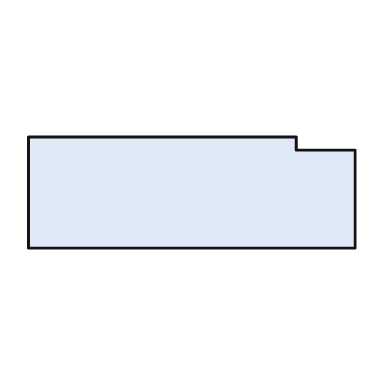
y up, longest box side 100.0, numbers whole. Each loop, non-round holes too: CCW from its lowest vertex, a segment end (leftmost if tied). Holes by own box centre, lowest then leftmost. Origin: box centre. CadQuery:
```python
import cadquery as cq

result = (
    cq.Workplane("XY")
    .moveTo(-50.0, -17.0)
    .lineTo(50.0, -17.0)
    .lineTo(50.0, 13.0)
    .lineTo(32.0, 13.0)
    .lineTo(32.0, 17.0)
    .lineTo(-50.0, 17.0)
    .close()
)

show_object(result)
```